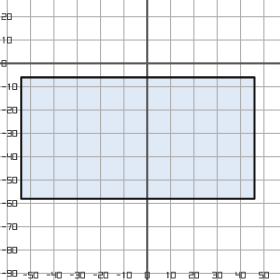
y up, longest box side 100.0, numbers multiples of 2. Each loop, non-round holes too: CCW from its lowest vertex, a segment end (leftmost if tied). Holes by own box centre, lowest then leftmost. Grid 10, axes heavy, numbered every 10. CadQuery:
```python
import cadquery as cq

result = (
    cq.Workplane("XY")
    .moveTo(-54.0, -58.0)
    .lineTo(46.0, -58.0)
    .lineTo(46.0, -6.0)
    .lineTo(-54.0, -6.0)
    .close()
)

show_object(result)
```